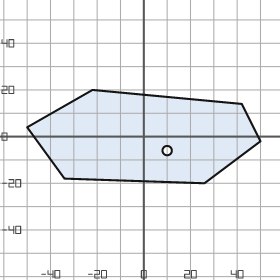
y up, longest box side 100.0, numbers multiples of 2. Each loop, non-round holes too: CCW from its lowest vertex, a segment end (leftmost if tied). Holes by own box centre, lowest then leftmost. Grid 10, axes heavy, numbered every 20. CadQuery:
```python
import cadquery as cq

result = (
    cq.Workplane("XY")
    .moveTo(26.0, -20.0)
    .lineTo(50.0, -2.0)
    .lineTo(42.0, 14.0)
    .lineTo(-22.0, 20.0)
    .lineTo(-50.0, 4.0)
    .lineTo(-34.0, -18.0)
    .close()
    .moveTo(10.0, -6.0)
    .circle(2.0)
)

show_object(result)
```